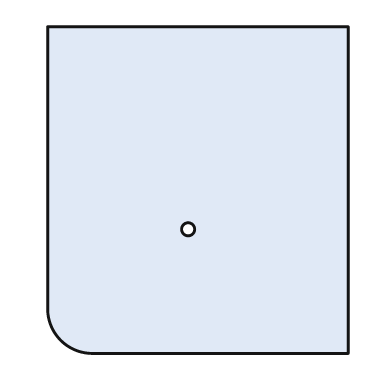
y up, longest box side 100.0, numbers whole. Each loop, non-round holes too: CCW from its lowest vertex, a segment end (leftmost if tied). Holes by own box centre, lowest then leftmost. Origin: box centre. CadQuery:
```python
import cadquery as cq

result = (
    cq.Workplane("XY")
    .moveTo(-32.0, -50.0)
    .lineTo(46.0, -50.0)
    .lineTo(46.0, 50.0)
    .lineTo(-46.0, 50.0)
    .lineTo(-46.0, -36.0)
    .threePointArc((-42.0, -46.0), (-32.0, -50.0))
    .close()
    .moveTo(-3.0, -12.0)
    .circle(2.0)
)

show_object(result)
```